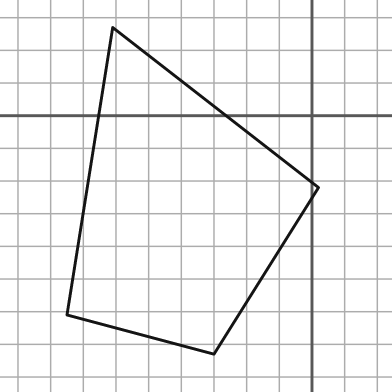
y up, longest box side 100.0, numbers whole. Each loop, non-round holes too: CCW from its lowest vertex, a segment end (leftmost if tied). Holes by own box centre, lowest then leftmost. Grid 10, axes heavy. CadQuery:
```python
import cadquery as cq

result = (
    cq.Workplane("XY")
    .moveTo(-30.0, -73.0)
    .lineTo(2.0, -22.0)
    .lineTo(-61.0, 27.0)
    .lineTo(-75.0, -61.0)
    .close()
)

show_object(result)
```